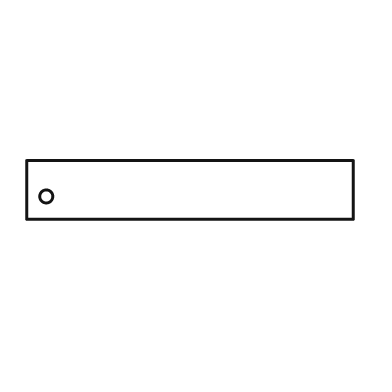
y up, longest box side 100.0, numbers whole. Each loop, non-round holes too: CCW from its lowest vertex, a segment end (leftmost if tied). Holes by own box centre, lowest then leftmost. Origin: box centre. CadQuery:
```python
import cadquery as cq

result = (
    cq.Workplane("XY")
    .moveTo(-50.0, -9.0)
    .lineTo(50.0, -9.0)
    .lineTo(50.0, 9.0)
    .lineTo(-50.0, 9.0)
    .close()
    .moveTo(-44.0, -2.0)
    .circle(2.0)
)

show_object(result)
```